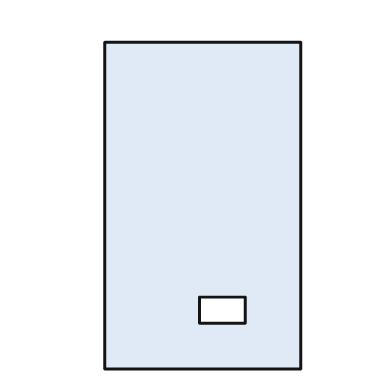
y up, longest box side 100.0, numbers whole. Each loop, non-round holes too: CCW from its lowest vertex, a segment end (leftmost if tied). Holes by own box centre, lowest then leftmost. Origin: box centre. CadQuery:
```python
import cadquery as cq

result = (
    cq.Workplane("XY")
    .moveTo(-30.0, -50.0)
    .lineTo(30.0, -50.0)
    .lineTo(30.0, 50.0)
    .lineTo(-30.0, 50.0)
    .close()
    .moveTo(-1.0, -36.0)
    .lineTo(13.0, -36.0)
    .lineTo(13.0, -28.0)
    .lineTo(-1.0, -28.0)
    .close()
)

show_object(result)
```